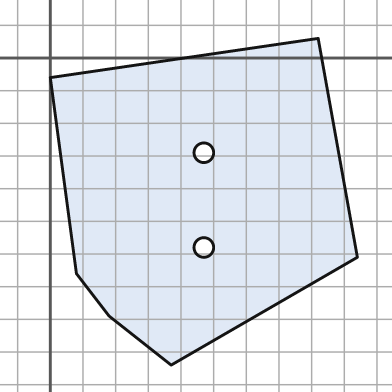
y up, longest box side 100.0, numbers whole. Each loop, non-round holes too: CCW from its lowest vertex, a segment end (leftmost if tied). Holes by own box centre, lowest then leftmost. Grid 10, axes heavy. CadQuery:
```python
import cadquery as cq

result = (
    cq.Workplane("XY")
    .moveTo(37.0, -94.0)
    .lineTo(94.0, -61.0)
    .lineTo(82.0, 6.0)
    .lineTo(0.0, -6.0)
    .lineTo(8.0, -66.0)
    .lineTo(18.0, -79.0)
    .close()
    .moveTo(47.0, -58.0)
    .circle(3.0)
    .moveTo(47.0, -29.0)
    .circle(3.0)
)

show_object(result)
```